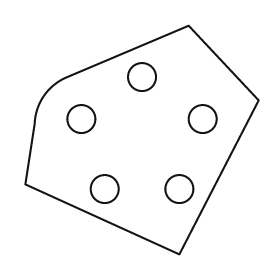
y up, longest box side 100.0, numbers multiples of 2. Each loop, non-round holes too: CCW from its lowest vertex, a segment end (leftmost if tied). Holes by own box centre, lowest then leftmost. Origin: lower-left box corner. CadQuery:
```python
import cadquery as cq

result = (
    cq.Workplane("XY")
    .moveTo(66.0, 0.0)
    .lineTo(100.0, 66.0)
    .lineTo(70.0, 98.0)
    .lineTo(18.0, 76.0)
    .threePointArc((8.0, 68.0), (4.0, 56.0))
    .lineTo(0.0, 30.0)
    .close()
    .moveTo(34.0, 28.0)
    .circle(6.0)
    .moveTo(66.0, 28.0)
    .circle(6.0)
    .moveTo(24.0, 58.0)
    .circle(6.0)
    .moveTo(76.0, 58.0)
    .circle(6.0)
    .moveTo(50.0, 76.0)
    .circle(6.0)
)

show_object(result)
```